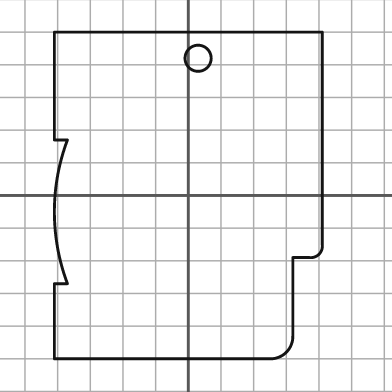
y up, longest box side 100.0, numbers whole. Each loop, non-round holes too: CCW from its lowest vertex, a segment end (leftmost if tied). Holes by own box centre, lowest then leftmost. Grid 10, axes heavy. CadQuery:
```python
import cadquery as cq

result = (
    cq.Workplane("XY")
    .moveTo(-41.0, -50.0)
    .lineTo(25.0, -50.0)
    .threePointArc((30.0, -48.0), (32.0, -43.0))
    .lineTo(32.0, -19.0)
    .lineTo(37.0, -19.0)
    .threePointArc((40.0, -18.0), (41.0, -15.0))
    .lineTo(41.0, 50.0)
    .lineTo(-41.0, 50.0)
    .lineTo(-41.0, 17.0)
    .lineTo(-37.0, 17.0)
    .threePointArc((-41.0, -5.0), (-37.0, -27.0))
    .lineTo(-41.0, -27.0)
    .close()
    .moveTo(3.0, 42.0)
    .circle(4.0)
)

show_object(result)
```